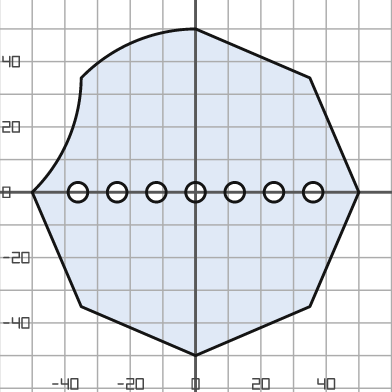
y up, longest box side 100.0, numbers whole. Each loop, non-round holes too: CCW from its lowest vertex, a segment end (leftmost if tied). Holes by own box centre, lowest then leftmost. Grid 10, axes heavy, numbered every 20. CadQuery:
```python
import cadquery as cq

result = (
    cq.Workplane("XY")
    .moveTo(0.0, -50.0)
    .lineTo(35.0, -35.0)
    .lineTo(50.0, 0.0)
    .lineTo(35.0, 35.0)
    .lineTo(0.0, 50.0)
    .threePointArc((-19.0, 46.0), (-35.0, 35.0))
    .threePointArc((-39.0, 16.0), (-50.0, 0.0))
    .lineTo(-35.0, -35.0)
    .close()
    .moveTo(-36.0, 0.0)
    .circle(3.0)
    .moveTo(-24.0, 0.0)
    .circle(3.0)
    .moveTo(-12.0, 0.0)
    .circle(3.0)
    .moveTo(0.0, 0.0)
    .circle(3.0)
    .moveTo(12.0, 0.0)
    .circle(3.0)
    .moveTo(24.0, 0.0)
    .circle(3.0)
    .moveTo(36.0, 0.0)
    .circle(3.0)
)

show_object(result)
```